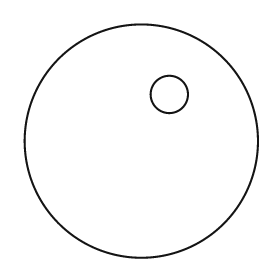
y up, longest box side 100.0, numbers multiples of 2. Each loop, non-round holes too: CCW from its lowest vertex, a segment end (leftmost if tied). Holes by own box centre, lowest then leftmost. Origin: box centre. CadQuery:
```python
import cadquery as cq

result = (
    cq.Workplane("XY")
    .moveTo(0.0, 0.0)
    .circle(50.0)
    .moveTo(12.0, 20.0)
    .circle(8.0)
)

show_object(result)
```